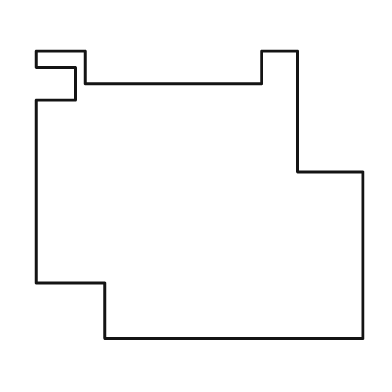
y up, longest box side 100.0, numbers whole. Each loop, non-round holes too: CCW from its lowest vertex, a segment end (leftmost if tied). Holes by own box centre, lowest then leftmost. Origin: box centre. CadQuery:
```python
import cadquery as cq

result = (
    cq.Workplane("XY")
    .moveTo(-29.0, -44.0)
    .lineTo(50.0, -44.0)
    .lineTo(50.0, 7.0)
    .lineTo(30.0, 7.0)
    .lineTo(30.0, 44.0)
    .lineTo(19.0, 44.0)
    .lineTo(19.0, 34.0)
    .lineTo(-35.0, 34.0)
    .lineTo(-35.0, 44.0)
    .lineTo(-50.0, 44.0)
    .lineTo(-50.0, 39.0)
    .lineTo(-38.0, 39.0)
    .lineTo(-38.0, 29.0)
    .lineTo(-50.0, 29.0)
    .lineTo(-50.0, -27.0)
    .lineTo(-29.0, -27.0)
    .close()
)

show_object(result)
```